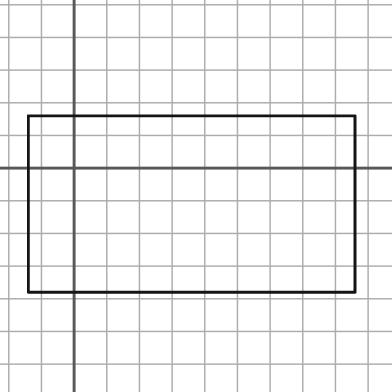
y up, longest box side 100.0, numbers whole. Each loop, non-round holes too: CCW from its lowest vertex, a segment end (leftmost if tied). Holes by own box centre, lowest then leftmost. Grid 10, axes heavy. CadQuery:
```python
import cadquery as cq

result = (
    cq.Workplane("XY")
    .moveTo(-14.0, -38.0)
    .lineTo(86.0, -38.0)
    .lineTo(86.0, 16.0)
    .lineTo(-14.0, 16.0)
    .close()
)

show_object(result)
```